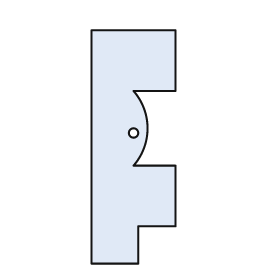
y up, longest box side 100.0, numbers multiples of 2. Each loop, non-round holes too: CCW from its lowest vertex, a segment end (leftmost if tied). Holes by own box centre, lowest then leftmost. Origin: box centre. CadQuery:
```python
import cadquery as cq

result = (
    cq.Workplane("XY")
    .moveTo(-18.0, -50.0)
    .lineTo(2.0, -50.0)
    .lineTo(2.0, -34.0)
    .lineTo(18.0, -34.0)
    .lineTo(18.0, -8.0)
    .lineTo(0.0, -8.0)
    .threePointArc((6.0, 8.0), (0.0, 24.0))
    .lineTo(18.0, 24.0)
    .lineTo(18.0, 50.0)
    .lineTo(-18.0, 50.0)
    .close()
    .moveTo(0.0, 6.0)
    .circle(2.0)
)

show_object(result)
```